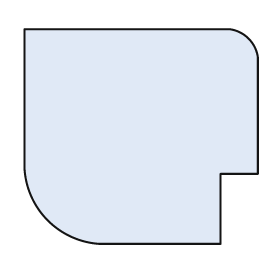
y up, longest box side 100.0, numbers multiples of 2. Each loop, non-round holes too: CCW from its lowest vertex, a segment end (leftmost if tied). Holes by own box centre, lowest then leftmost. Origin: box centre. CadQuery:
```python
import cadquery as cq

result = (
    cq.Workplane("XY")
    .moveTo(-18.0, -46.0)
    .lineTo(34.0, -46.0)
    .lineTo(34.0, -16.0)
    .lineTo(50.0, -16.0)
    .lineTo(50.0, 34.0)
    .threePointArc((46.0, 42.0), (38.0, 46.0))
    .lineTo(-50.0, 46.0)
    .lineTo(-50.0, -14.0)
    .threePointArc((-40.0, -36.0), (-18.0, -46.0))
    .close()
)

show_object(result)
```